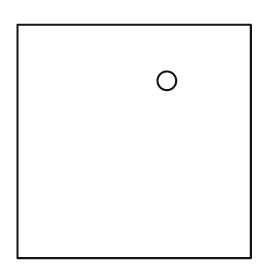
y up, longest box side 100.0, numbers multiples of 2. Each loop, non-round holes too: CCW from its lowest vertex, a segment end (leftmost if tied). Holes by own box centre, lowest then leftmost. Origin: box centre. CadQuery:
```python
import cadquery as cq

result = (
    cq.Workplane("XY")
    .moveTo(-50.0, -50.0)
    .lineTo(50.0, -50.0)
    .lineTo(50.0, 50.0)
    .lineTo(-50.0, 50.0)
    .close()
    .moveTo(14.0, 26.0)
    .circle(4.0)
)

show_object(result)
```